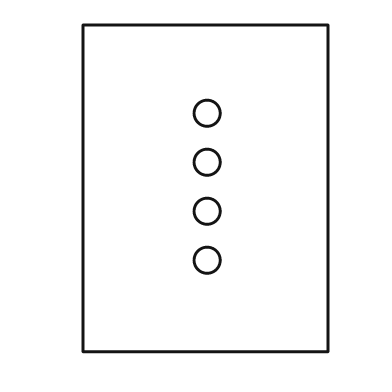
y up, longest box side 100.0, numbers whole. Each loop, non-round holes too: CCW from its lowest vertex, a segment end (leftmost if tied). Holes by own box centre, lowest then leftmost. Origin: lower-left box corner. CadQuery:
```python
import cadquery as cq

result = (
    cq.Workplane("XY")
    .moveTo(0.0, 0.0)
    .lineTo(75.0, 0.0)
    .lineTo(75.0, 100.0)
    .lineTo(0.0, 100.0)
    .close()
    .moveTo(38.0, 28.0)
    .circle(4.0)
    .moveTo(38.0, 43.0)
    .circle(4.0)
    .moveTo(38.0, 58.0)
    .circle(4.0)
    .moveTo(38.0, 73.0)
    .circle(4.0)
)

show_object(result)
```